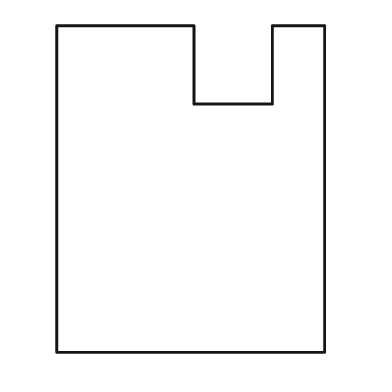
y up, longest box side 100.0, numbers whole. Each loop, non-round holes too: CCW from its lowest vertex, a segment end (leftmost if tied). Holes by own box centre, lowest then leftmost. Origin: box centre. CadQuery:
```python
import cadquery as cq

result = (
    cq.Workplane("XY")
    .moveTo(-41.0, -50.0)
    .lineTo(41.0, -50.0)
    .lineTo(41.0, 50.0)
    .lineTo(25.0, 50.0)
    .lineTo(25.0, 26.0)
    .lineTo(1.0, 26.0)
    .lineTo(1.0, 50.0)
    .lineTo(-41.0, 50.0)
    .close()
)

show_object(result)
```